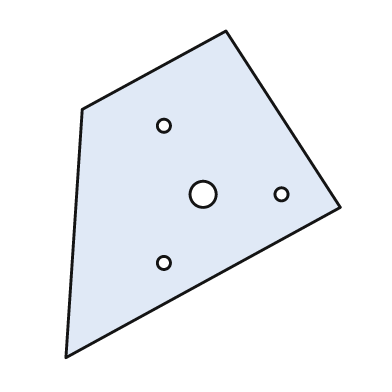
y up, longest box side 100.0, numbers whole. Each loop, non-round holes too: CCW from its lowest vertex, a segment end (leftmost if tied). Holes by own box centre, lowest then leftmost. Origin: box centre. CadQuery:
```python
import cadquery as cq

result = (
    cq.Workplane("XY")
    .moveTo(-42.0, -50.0)
    .lineTo(42.0, -4.0)
    .lineTo(7.0, 50.0)
    .lineTo(-37.0, 26.0)
    .close()
    .moveTo(-12.0, -21.0)
    .circle(2.0)
    .moveTo(0.0, 0.0)
    .circle(4.0)
    .moveTo(24.0, 0.0)
    .circle(2.0)
    .moveTo(-12.0, 21.0)
    .circle(2.0)
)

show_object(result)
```